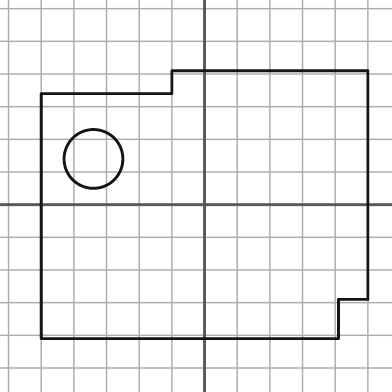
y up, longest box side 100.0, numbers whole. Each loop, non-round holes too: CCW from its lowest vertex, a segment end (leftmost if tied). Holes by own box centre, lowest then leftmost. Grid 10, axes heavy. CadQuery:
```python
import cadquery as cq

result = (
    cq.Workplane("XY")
    .moveTo(-50.0, -41.0)
    .lineTo(41.0, -41.0)
    .lineTo(41.0, -29.0)
    .lineTo(50.0, -29.0)
    .lineTo(50.0, 41.0)
    .lineTo(-10.0, 41.0)
    .lineTo(-10.0, 34.0)
    .lineTo(-50.0, 34.0)
    .close()
    .moveTo(-34.0, 14.0)
    .circle(9.0)
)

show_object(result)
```